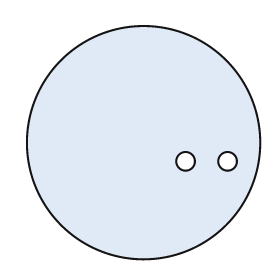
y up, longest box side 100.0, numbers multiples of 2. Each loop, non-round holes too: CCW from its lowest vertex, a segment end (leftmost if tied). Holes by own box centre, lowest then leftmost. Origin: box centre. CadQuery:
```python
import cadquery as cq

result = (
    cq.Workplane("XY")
    .moveTo(0.0, 0.0)
    .circle(50.0)
    .moveTo(18.0, -8.0)
    .circle(4.0)
    .moveTo(36.0, -8.0)
    .circle(4.0)
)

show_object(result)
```